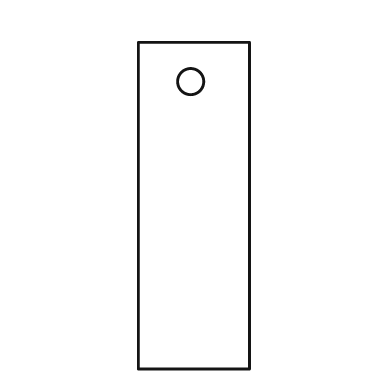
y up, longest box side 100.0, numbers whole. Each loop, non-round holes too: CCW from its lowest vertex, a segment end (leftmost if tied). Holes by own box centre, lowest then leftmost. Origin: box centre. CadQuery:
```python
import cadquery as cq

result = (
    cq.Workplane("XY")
    .moveTo(-17.0, -50.0)
    .lineTo(17.0, -50.0)
    .lineTo(17.0, 50.0)
    .lineTo(-17.0, 50.0)
    .close()
    .moveTo(-1.0, 38.0)
    .circle(4.0)
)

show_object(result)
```